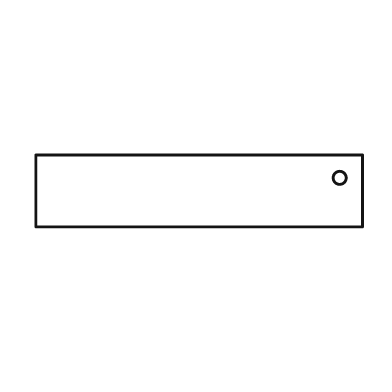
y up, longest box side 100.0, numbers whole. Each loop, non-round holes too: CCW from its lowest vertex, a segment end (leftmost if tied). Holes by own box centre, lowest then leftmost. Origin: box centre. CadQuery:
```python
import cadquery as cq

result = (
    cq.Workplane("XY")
    .moveTo(-50.0, -11.0)
    .lineTo(50.0, -11.0)
    .lineTo(50.0, 11.0)
    .lineTo(-50.0, 11.0)
    .close()
    .moveTo(43.0, 4.0)
    .circle(2.0)
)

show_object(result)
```